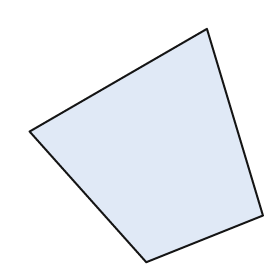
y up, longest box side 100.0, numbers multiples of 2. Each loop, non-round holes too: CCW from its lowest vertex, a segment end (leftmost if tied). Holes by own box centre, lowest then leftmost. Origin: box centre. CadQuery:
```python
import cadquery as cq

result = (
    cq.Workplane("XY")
    .moveTo(0.0, -50.0)
    .lineTo(50.0, -30.0)
    .lineTo(26.0, 50.0)
    .lineTo(-50.0, 6.0)
    .close()
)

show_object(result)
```